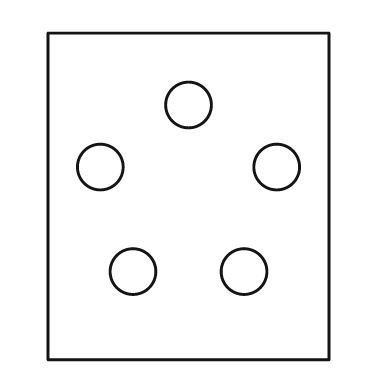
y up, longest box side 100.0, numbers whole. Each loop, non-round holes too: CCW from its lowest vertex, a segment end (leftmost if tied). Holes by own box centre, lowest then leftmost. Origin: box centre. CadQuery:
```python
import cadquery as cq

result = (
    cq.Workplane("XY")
    .moveTo(-43.0, -50.0)
    .lineTo(43.0, -50.0)
    .lineTo(43.0, 50.0)
    .lineTo(-43.0, 50.0)
    .close()
    .moveTo(-17.0, -23.0)
    .circle(7.0)
    .moveTo(17.0, -23.0)
    .circle(7.0)
    .moveTo(-27.0, 9.0)
    .circle(7.0)
    .moveTo(27.0, 9.0)
    .circle(7.0)
    .moveTo(0.0, 28.0)
    .circle(7.0)
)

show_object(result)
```